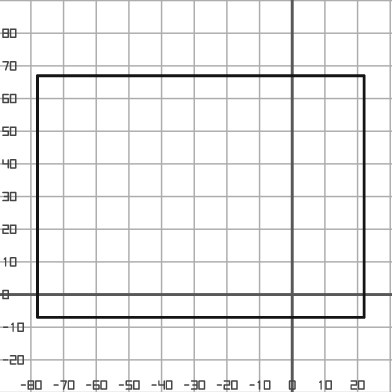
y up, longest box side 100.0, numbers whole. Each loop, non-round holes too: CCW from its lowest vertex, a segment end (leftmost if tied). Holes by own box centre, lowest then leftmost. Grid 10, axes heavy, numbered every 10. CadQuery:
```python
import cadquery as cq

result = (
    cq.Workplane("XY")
    .moveTo(-78.0, -7.0)
    .lineTo(22.0, -7.0)
    .lineTo(22.0, 67.0)
    .lineTo(-78.0, 67.0)
    .close()
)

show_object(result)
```